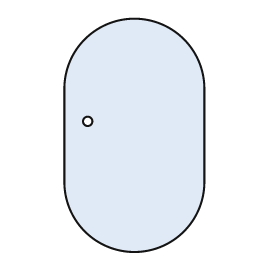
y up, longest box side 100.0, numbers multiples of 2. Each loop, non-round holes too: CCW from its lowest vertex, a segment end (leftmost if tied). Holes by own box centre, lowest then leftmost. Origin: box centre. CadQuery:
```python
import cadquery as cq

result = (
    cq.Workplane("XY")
    .moveTo(-30.0, -20.0)
    .threePointArc((0.0, -50.0), (30.0, -20.0))
    .lineTo(30.0, 20.0)
    .threePointArc((0.0, 50.0), (-30.0, 20.0))
    .close()
    .moveTo(-20.0, 6.0)
    .circle(2.0)
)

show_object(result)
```